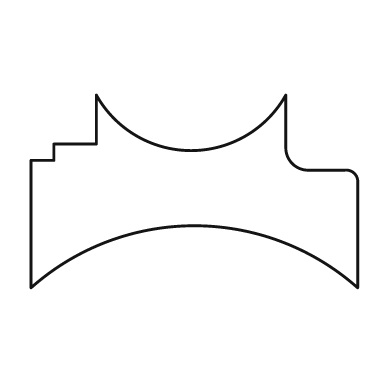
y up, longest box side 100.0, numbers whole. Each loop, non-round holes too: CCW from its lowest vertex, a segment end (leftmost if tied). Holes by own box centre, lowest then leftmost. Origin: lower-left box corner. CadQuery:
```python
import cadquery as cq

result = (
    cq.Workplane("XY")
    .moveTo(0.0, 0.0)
    .threePointArc((50.0, 19.0), (100.0, 0.0))
    .lineTo(100.0, 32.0)
    .threePointArc((99.0, 35.0), (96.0, 36.0))
    .lineTo(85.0, 36.0)
    .threePointArc((80.0, 38.0), (78.0, 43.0))
    .lineTo(78.0, 59.0)
    .threePointArc((49.0, 42.0), (20.0, 59.0))
    .lineTo(20.0, 44.0)
    .lineTo(7.0, 44.0)
    .lineTo(7.0, 39.0)
    .lineTo(0.0, 39.0)
    .close()
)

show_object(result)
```